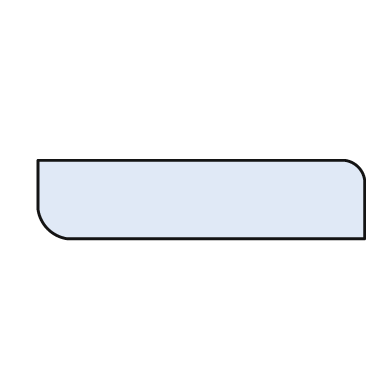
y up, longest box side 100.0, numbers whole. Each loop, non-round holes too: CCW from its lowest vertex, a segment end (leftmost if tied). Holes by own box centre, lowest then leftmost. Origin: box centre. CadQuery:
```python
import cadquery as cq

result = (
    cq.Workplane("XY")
    .moveTo(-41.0, -12.0)
    .lineTo(50.0, -12.0)
    .lineTo(50.0, 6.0)
    .threePointArc((48.0, 10.0), (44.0, 12.0))
    .lineTo(-50.0, 12.0)
    .lineTo(-50.0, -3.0)
    .threePointArc((-47.0, -9.0), (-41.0, -12.0))
    .close()
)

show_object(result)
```